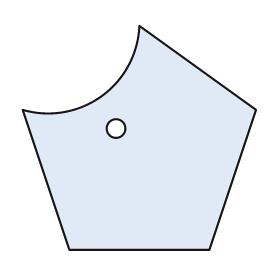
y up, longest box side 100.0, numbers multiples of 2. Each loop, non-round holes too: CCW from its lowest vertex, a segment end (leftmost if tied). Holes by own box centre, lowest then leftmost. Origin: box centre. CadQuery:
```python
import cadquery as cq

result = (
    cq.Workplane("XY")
    .moveTo(-30.0, -48.0)
    .lineTo(30.0, -48.0)
    .lineTo(50.0, 12.0)
    .lineTo(0.0, 48.0)
    .threePointArc((-16.0, 18.0), (-50.0, 12.0))
    .close()
    .moveTo(-10.0, 4.0)
    .circle(4.0)
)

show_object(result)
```